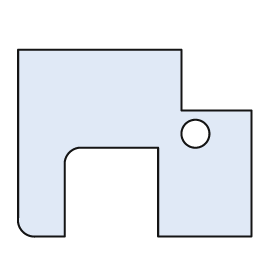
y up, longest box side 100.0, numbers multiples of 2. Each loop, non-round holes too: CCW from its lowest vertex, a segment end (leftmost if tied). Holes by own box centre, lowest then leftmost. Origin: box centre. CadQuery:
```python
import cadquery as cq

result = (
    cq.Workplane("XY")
    .moveTo(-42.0, -40.0)
    .lineTo(-30.0, -40.0)
    .lineTo(-30.0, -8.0)
    .threePointArc((-28.0, -4.0), (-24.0, -2.0))
    .lineTo(10.0, -2.0)
    .lineTo(10.0, -40.0)
    .lineTo(50.0, -40.0)
    .lineTo(50.0, 14.0)
    .lineTo(20.0, 14.0)
    .lineTo(20.0, 40.0)
    .lineTo(-50.0, 40.0)
    .lineTo(-50.0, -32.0)
    .threePointArc((-48.0, -38.0), (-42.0, -40.0))
    .close()
    .moveTo(26.0, 4.0)
    .circle(6.0)
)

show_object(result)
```